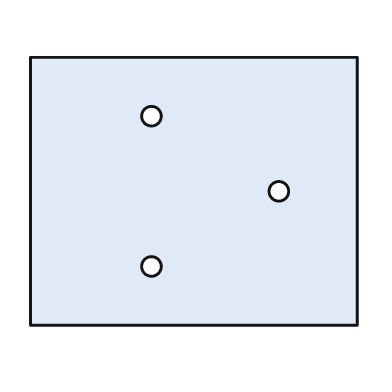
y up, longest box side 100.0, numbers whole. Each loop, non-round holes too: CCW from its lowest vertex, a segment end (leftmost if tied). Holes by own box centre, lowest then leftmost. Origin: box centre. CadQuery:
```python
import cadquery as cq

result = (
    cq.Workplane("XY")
    .moveTo(-50.0, -41.0)
    .lineTo(50.0, -41.0)
    .lineTo(50.0, 41.0)
    .lineTo(-50.0, 41.0)
    .close()
    .moveTo(-13.0, -23.0)
    .circle(3.0)
    .moveTo(26.0, 0.0)
    .circle(3.0)
    .moveTo(-13.0, 23.0)
    .circle(3.0)
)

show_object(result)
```